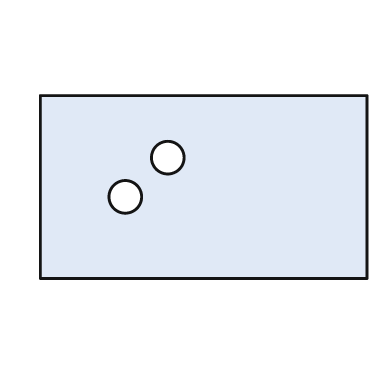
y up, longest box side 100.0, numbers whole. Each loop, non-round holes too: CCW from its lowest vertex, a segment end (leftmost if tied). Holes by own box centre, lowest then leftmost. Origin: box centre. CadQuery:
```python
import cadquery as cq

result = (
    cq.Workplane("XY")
    .moveTo(-50.0, -28.0)
    .lineTo(50.0, -28.0)
    .lineTo(50.0, 28.0)
    .lineTo(-50.0, 28.0)
    .close()
    .moveTo(-24.0, -3.0)
    .circle(5.0)
    .moveTo(-11.0, 9.0)
    .circle(5.0)
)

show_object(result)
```